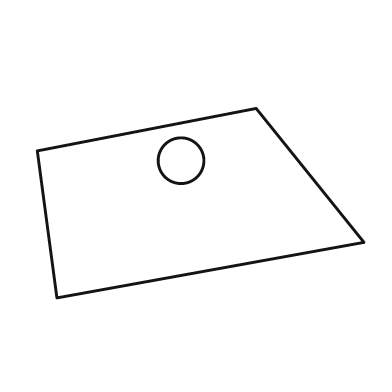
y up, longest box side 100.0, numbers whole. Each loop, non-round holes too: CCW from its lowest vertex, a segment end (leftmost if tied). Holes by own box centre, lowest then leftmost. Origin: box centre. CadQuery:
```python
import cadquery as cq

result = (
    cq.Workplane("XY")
    .moveTo(-44.0, -29.0)
    .lineTo(50.0, -12.0)
    .lineTo(17.0, 29.0)
    .lineTo(-50.0, 16.0)
    .close()
    .moveTo(-6.0, 13.0)
    .circle(7.0)
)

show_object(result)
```